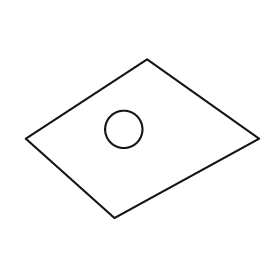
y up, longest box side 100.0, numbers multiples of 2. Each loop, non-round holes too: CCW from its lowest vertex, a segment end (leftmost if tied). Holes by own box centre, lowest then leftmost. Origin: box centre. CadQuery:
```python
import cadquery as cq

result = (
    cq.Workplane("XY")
    .moveTo(-12.0, -34.0)
    .lineTo(50.0, 0.0)
    .lineTo(2.0, 34.0)
    .lineTo(-50.0, 0.0)
    .close()
    .moveTo(-8.0, 4.0)
    .circle(8.0)
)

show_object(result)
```